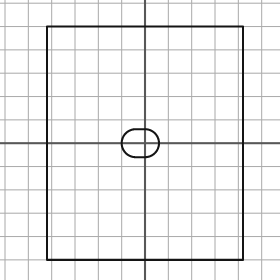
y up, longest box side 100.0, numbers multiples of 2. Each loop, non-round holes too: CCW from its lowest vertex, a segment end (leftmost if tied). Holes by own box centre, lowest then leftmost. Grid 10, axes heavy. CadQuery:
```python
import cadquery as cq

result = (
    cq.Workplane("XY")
    .moveTo(-42.0, -50.0)
    .lineTo(42.0, -50.0)
    .lineTo(42.0, 50.0)
    .lineTo(-42.0, 50.0)
    .close()
    .moveTo(-4.0, -6.0)
    .lineTo(0.0, -6.0)
    .threePointArc((6.0, 0.0), (0.0, 6.0))
    .lineTo(-4.0, 6.0)
    .threePointArc((-10.0, 0.0), (-4.0, -6.0))
    .close()
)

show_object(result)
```